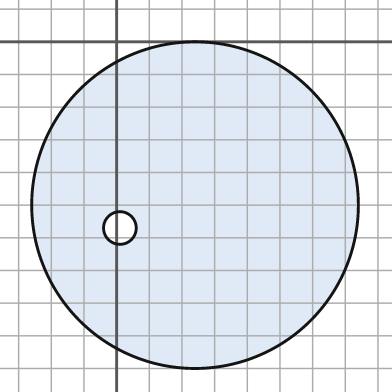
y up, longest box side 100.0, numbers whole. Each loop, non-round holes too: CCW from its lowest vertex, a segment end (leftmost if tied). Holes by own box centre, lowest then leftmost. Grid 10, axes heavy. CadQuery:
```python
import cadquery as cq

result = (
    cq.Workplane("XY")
    .moveTo(24.0, -50.0)
    .circle(50.0)
    .moveTo(1.0, -57.0)
    .circle(5.0)
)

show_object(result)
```